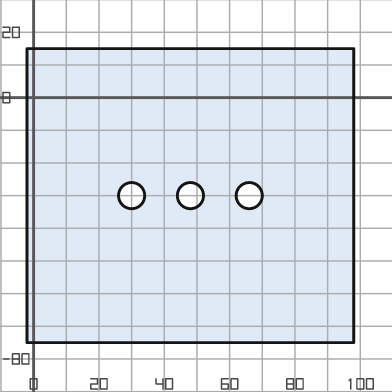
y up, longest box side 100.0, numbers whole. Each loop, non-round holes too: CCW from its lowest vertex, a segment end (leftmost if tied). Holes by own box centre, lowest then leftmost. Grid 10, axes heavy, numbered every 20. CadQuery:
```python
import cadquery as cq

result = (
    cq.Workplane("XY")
    .moveTo(-2.0, -75.0)
    .lineTo(98.0, -75.0)
    .lineTo(98.0, 15.0)
    .lineTo(-2.0, 15.0)
    .close()
    .moveTo(30.0, -30.0)
    .circle(4.0)
    .moveTo(48.0, -30.0)
    .circle(4.0)
    .moveTo(66.0, -30.0)
    .circle(4.0)
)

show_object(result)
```